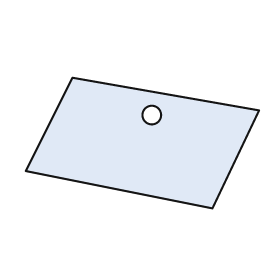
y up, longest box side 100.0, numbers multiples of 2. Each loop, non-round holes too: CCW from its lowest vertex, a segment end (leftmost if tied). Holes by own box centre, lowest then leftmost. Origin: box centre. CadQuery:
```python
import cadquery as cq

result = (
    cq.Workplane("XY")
    .moveTo(30.0, -28.0)
    .lineTo(50.0, 14.0)
    .lineTo(-30.0, 28.0)
    .lineTo(-50.0, -12.0)
    .close()
    .moveTo(4.0, 12.0)
    .circle(4.0)
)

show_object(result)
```